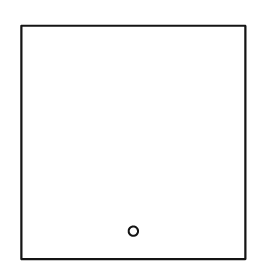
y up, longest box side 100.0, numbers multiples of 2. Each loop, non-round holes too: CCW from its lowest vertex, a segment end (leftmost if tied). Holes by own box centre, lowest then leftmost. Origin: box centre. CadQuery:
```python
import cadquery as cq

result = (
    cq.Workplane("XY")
    .moveTo(-48.0, -50.0)
    .lineTo(48.0, -50.0)
    .lineTo(48.0, 50.0)
    .lineTo(-48.0, 50.0)
    .close()
    .moveTo(0.0, -38.0)
    .circle(2.0)
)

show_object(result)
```